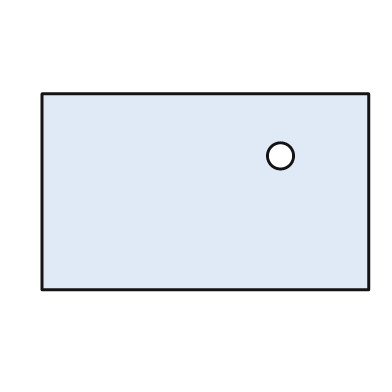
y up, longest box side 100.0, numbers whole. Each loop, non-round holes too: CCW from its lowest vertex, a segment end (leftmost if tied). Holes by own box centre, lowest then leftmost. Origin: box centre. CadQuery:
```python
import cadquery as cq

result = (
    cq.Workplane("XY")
    .moveTo(-50.0, -30.0)
    .lineTo(50.0, -30.0)
    .lineTo(50.0, 30.0)
    .lineTo(-50.0, 30.0)
    .close()
    .moveTo(23.0, 11.0)
    .circle(4.0)
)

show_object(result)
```